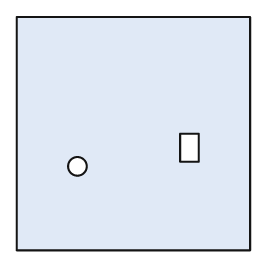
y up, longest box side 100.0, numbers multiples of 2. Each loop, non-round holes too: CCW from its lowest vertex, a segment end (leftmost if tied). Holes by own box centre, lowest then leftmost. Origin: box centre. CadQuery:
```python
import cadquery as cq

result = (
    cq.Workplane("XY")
    .moveTo(-50.0, -50.0)
    .lineTo(50.0, -50.0)
    .lineTo(50.0, 50.0)
    .lineTo(-50.0, 50.0)
    .close()
    .moveTo(-24.0, -14.0)
    .circle(4.0)
    .moveTo(20.0, -12.0)
    .lineTo(28.0, -12.0)
    .lineTo(28.0, 0.0)
    .lineTo(20.0, 0.0)
    .close()
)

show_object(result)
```